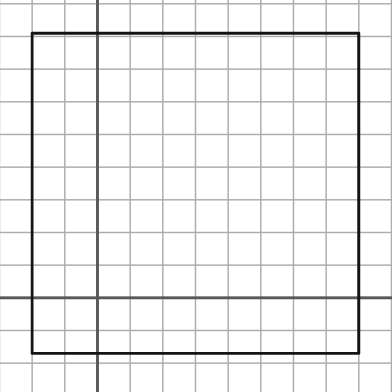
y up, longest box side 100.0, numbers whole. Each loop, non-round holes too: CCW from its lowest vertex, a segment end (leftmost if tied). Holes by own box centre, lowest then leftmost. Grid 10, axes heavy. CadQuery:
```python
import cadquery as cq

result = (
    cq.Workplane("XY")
    .moveTo(-20.0, -17.0)
    .lineTo(80.0, -17.0)
    .lineTo(80.0, 81.0)
    .lineTo(-20.0, 81.0)
    .close()
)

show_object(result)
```